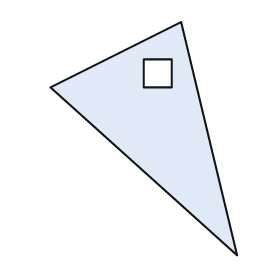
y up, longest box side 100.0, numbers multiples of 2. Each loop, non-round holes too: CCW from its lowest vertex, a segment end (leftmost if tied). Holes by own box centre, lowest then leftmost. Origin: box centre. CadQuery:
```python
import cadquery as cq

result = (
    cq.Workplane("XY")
    .moveTo(40.0, -50.0)
    .lineTo(16.0, 50.0)
    .lineTo(-40.0, 22.0)
    .close()
    .moveTo(0.0, 22.0)
    .lineTo(12.0, 22.0)
    .lineTo(12.0, 34.0)
    .lineTo(0.0, 34.0)
    .close()
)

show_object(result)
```